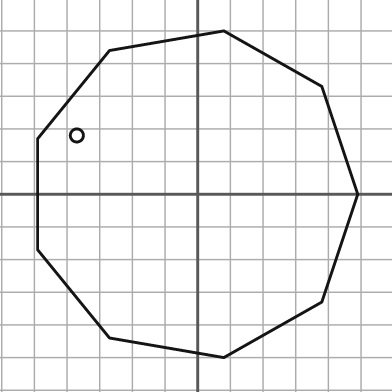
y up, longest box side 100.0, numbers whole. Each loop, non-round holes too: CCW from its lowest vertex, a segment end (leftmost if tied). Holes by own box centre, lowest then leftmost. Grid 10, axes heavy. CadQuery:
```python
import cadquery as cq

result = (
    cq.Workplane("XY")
    .moveTo(8.0, -50.0)
    .lineTo(38.0, -33.0)
    .lineTo(49.0, 0.0)
    .lineTo(38.0, 33.0)
    .lineTo(8.0, 50.0)
    .lineTo(-27.0, 44.0)
    .lineTo(-49.0, 17.0)
    .lineTo(-49.0, -17.0)
    .lineTo(-27.0, -44.0)
    .close()
    .moveTo(-37.0, 18.0)
    .circle(2.0)
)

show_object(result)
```